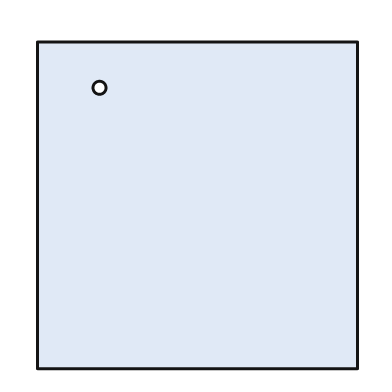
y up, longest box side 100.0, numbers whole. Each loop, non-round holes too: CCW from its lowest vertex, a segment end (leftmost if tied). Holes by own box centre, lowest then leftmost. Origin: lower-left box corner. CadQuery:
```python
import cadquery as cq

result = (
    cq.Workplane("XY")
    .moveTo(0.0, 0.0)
    .lineTo(98.0, 0.0)
    .lineTo(98.0, 100.0)
    .lineTo(0.0, 100.0)
    .close()
    .moveTo(19.0, 86.0)
    .circle(2.0)
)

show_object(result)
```